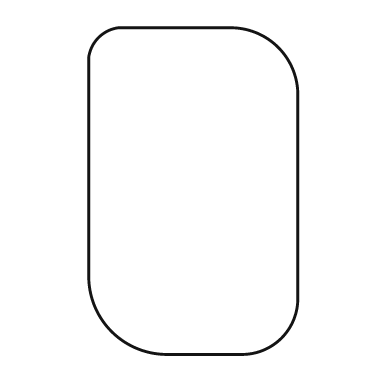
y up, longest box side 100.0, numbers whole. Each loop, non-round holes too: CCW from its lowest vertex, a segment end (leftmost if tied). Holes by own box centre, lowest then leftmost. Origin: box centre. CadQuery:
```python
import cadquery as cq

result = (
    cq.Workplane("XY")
    .moveTo(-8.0, -50.0)
    .lineTo(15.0, -50.0)
    .threePointArc((27.0, -45.0), (32.0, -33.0))
    .lineTo(32.0, 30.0)
    .threePointArc((26.0, 44.0), (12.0, 50.0))
    .lineTo(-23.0, 50.0)
    .threePointArc((-29.0, 47.0), (-32.0, 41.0))
    .lineTo(-32.0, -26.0)
    .threePointArc((-25.0, -43.0), (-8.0, -50.0))
    .close()
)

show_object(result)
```